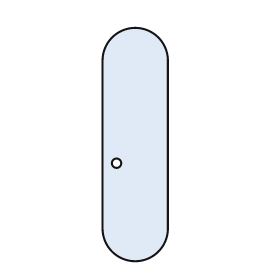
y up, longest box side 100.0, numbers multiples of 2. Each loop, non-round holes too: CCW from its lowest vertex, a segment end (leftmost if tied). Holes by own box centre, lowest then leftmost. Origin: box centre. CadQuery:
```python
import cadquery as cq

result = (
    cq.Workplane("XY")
    .moveTo(-14.0, -36.0)
    .threePointArc((0.0, -50.0), (14.0, -36.0))
    .lineTo(14.0, 36.0)
    .threePointArc((0.0, 50.0), (-14.0, 36.0))
    .close()
    .moveTo(-8.0, -8.0)
    .circle(2.0)
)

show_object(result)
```